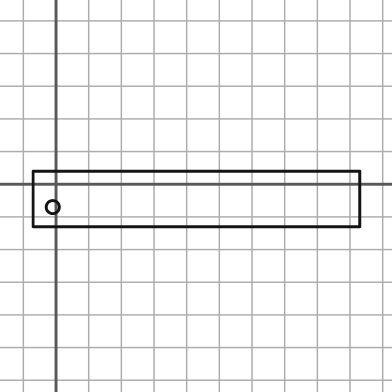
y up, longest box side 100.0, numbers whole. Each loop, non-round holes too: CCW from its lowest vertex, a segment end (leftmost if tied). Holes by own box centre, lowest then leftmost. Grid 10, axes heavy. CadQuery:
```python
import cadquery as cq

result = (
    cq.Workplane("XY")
    .moveTo(-7.0, -13.0)
    .lineTo(93.0, -13.0)
    .lineTo(93.0, 4.0)
    .lineTo(-7.0, 4.0)
    .close()
    .moveTo(-1.0, -7.0)
    .circle(2.0)
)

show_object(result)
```